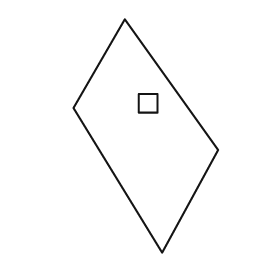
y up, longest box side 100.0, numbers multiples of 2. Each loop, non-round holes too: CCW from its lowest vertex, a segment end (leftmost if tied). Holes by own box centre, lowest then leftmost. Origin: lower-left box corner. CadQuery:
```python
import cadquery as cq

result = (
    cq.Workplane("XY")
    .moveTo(38.0, 0.0)
    .lineTo(62.0, 44.0)
    .lineTo(22.0, 100.0)
    .lineTo(0.0, 62.0)
    .close()
    .moveTo(28.0, 60.0)
    .lineTo(36.0, 60.0)
    .lineTo(36.0, 68.0)
    .lineTo(28.0, 68.0)
    .close()
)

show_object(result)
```